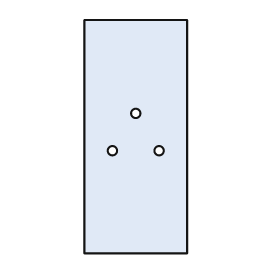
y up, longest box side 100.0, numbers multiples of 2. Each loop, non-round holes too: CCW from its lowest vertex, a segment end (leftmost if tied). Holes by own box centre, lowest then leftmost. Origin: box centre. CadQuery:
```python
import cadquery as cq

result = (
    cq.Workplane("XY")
    .moveTo(-22.0, -50.0)
    .lineTo(22.0, -50.0)
    .lineTo(22.0, 50.0)
    .lineTo(-22.0, 50.0)
    .close()
    .moveTo(-10.0, -6.0)
    .circle(2.0)
    .moveTo(10.0, -6.0)
    .circle(2.0)
    .moveTo(0.0, 10.0)
    .circle(2.0)
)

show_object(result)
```